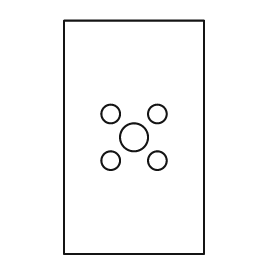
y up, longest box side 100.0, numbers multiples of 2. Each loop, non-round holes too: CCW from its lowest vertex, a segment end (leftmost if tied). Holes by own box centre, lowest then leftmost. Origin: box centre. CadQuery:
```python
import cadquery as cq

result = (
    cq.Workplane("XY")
    .moveTo(-30.0, -50.0)
    .lineTo(30.0, -50.0)
    .lineTo(30.0, 50.0)
    .lineTo(-30.0, 50.0)
    .close()
    .moveTo(-10.0, -10.0)
    .circle(4.0)
    .moveTo(10.0, -10.0)
    .circle(4.0)
    .moveTo(0.0, 0.0)
    .circle(6.0)
    .moveTo(-10.0, 10.0)
    .circle(4.0)
    .moveTo(10.0, 10.0)
    .circle(4.0)
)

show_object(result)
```